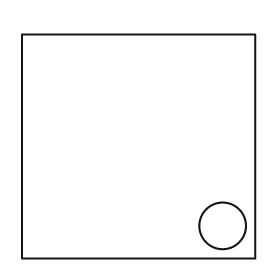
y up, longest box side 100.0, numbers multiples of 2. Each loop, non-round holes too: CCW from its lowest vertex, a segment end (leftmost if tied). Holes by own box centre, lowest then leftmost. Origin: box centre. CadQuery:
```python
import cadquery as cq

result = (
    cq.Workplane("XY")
    .moveTo(-50.0, -48.0)
    .lineTo(50.0, -48.0)
    .lineTo(50.0, 48.0)
    .lineTo(-50.0, 48.0)
    .close()
    .moveTo(36.0, -34.0)
    .circle(10.0)
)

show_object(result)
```